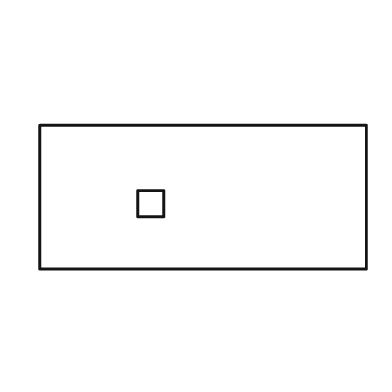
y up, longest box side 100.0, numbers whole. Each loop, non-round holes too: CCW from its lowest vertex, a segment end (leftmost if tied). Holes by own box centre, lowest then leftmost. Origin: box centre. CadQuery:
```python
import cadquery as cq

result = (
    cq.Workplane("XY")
    .moveTo(-50.0, -22.0)
    .lineTo(50.0, -22.0)
    .lineTo(50.0, 22.0)
    .lineTo(-50.0, 22.0)
    .close()
    .moveTo(-20.0, -6.0)
    .lineTo(-12.0, -6.0)
    .lineTo(-12.0, 2.0)
    .lineTo(-20.0, 2.0)
    .close()
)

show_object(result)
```